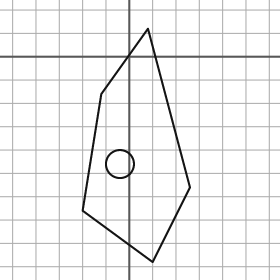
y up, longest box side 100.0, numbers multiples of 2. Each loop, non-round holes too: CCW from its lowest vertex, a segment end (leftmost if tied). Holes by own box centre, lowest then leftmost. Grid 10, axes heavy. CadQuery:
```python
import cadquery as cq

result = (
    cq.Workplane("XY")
    .moveTo(10.0, -88.0)
    .lineTo(26.0, -56.0)
    .lineTo(8.0, 12.0)
    .lineTo(-12.0, -16.0)
    .lineTo(-20.0, -66.0)
    .close()
    .moveTo(-4.0, -46.0)
    .circle(6.0)
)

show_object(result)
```